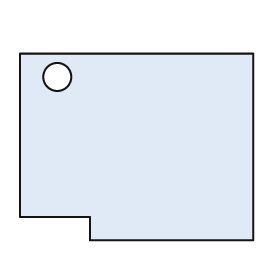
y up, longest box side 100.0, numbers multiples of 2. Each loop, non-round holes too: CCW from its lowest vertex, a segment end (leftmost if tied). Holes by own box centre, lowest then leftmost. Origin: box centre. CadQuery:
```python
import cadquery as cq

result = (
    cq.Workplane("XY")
    .moveTo(-20.0, -40.0)
    .lineTo(50.0, -40.0)
    .lineTo(50.0, 40.0)
    .lineTo(-50.0, 40.0)
    .lineTo(-50.0, -30.0)
    .lineTo(-20.0, -30.0)
    .close()
    .moveTo(-34.0, 30.0)
    .circle(6.0)
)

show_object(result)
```